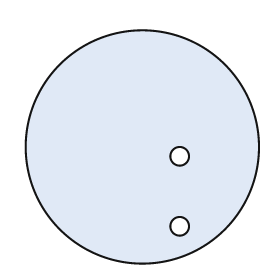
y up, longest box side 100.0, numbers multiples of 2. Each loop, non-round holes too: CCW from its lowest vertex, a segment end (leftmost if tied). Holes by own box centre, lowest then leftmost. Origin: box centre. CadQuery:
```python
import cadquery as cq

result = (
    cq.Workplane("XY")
    .moveTo(0.0, 0.0)
    .circle(50.0)
    .moveTo(16.0, -34.0)
    .circle(4.0)
    .moveTo(16.0, -4.0)
    .circle(4.0)
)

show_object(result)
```